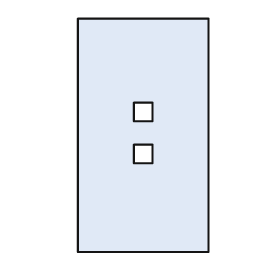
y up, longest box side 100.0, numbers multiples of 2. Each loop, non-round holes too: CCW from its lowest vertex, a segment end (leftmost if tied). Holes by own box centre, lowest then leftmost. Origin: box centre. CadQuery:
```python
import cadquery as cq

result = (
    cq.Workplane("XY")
    .moveTo(-28.0, -50.0)
    .lineTo(28.0, -50.0)
    .lineTo(28.0, 50.0)
    .lineTo(-28.0, 50.0)
    .close()
    .moveTo(-4.0, -12.0)
    .lineTo(4.0, -12.0)
    .lineTo(4.0, -4.0)
    .lineTo(-4.0, -4.0)
    .close()
    .moveTo(-4.0, 6.0)
    .lineTo(4.0, 6.0)
    .lineTo(4.0, 14.0)
    .lineTo(-4.0, 14.0)
    .close()
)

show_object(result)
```